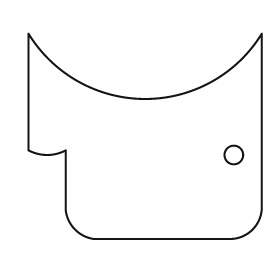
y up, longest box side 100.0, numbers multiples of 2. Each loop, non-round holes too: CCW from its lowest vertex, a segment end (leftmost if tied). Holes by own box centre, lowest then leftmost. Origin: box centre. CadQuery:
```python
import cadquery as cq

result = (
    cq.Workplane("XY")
    .moveTo(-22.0, -44.0)
    .lineTo(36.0, -44.0)
    .threePointArc((46.0, -40.0), (50.0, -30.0))
    .lineTo(50.0, 44.0)
    .threePointArc((0.0, 16.0), (-50.0, 44.0))
    .lineTo(-50.0, -6.0)
    .threePointArc((-42.0, -8.0), (-34.0, -6.0))
    .lineTo(-34.0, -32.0)
    .threePointArc((-30.0, -40.0), (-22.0, -44.0))
    .close()
    .moveTo(38.0, -8.0)
    .circle(4.0)
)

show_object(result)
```